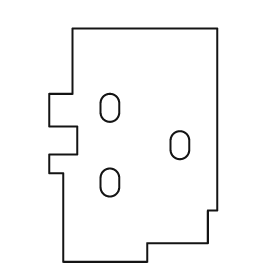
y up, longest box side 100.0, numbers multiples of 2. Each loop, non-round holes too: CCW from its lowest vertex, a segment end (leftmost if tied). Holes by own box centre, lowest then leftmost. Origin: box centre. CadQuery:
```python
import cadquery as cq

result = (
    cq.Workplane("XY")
    .moveTo(-30.0, -50.0)
    .lineTo(6.0, -50.0)
    .lineTo(6.0, -42.0)
    .lineTo(32.0, -42.0)
    .lineTo(32.0, -28.0)
    .lineTo(36.0, -28.0)
    .lineTo(36.0, 50.0)
    .lineTo(-26.0, 50.0)
    .lineTo(-26.0, 22.0)
    .lineTo(-36.0, 22.0)
    .lineTo(-36.0, 8.0)
    .lineTo(-24.0, 8.0)
    .lineTo(-24.0, -4.0)
    .lineTo(-36.0, -4.0)
    .lineTo(-36.0, -12.0)
    .lineTo(-30.0, -12.0)
    .close()
    .moveTo(-14.0, -18.0)
    .threePointArc((-10.0, -22.0), (-6.0, -18.0))
    .lineTo(-6.0, -14.0)
    .threePointArc((-10.0, -10.0), (-14.0, -14.0))
    .close()
    .moveTo(16.0, -2.0)
    .threePointArc((20.0, -6.0), (24.0, -2.0))
    .lineTo(24.0, 2.0)
    .threePointArc((20.0, 6.0), (16.0, 2.0))
    .close()
    .moveTo(-14.0, 14.0)
    .threePointArc((-10.0, 10.0), (-6.0, 14.0))
    .lineTo(-6.0, 18.0)
    .threePointArc((-10.0, 22.0), (-14.0, 18.0))
    .close()
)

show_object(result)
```